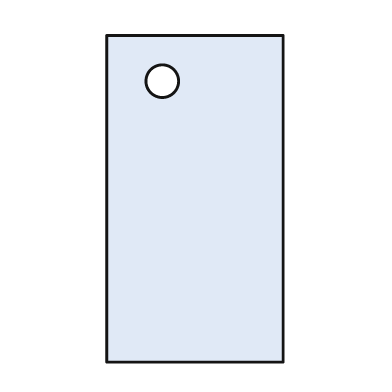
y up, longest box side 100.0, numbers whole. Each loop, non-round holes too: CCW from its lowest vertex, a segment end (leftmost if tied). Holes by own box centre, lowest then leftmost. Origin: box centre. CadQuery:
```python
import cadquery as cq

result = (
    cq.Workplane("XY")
    .moveTo(-27.0, -50.0)
    .lineTo(27.0, -50.0)
    .lineTo(27.0, 50.0)
    .lineTo(-27.0, 50.0)
    .close()
    .moveTo(-10.0, 36.0)
    .circle(5.0)
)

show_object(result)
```